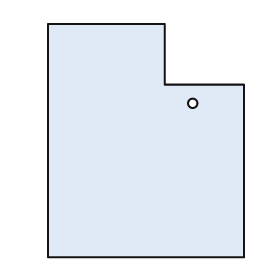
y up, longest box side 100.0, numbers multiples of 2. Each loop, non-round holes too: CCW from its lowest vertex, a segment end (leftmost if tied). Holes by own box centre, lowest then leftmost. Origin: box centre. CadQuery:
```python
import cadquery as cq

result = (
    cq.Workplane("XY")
    .moveTo(-42.0, -50.0)
    .lineTo(42.0, -50.0)
    .lineTo(42.0, 24.0)
    .lineTo(8.0, 24.0)
    .lineTo(8.0, 50.0)
    .lineTo(-42.0, 50.0)
    .close()
    .moveTo(20.0, 16.0)
    .circle(2.0)
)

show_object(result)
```